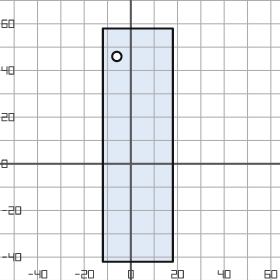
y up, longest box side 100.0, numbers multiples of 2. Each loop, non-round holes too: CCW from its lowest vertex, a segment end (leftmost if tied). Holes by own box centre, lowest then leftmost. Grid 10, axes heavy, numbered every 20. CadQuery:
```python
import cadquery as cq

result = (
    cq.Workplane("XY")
    .moveTo(-12.0, -42.0)
    .lineTo(18.0, -42.0)
    .lineTo(18.0, 58.0)
    .lineTo(-12.0, 58.0)
    .close()
    .moveTo(-6.0, 46.0)
    .circle(2.0)
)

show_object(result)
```